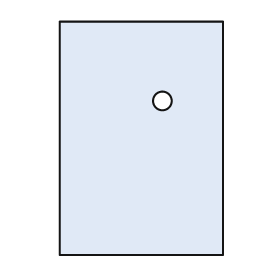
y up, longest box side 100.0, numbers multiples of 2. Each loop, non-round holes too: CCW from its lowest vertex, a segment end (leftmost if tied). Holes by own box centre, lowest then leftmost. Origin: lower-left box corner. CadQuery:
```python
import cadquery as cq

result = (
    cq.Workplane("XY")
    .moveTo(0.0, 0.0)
    .lineTo(70.0, 0.0)
    .lineTo(70.0, 100.0)
    .lineTo(0.0, 100.0)
    .close()
    .moveTo(44.0, 66.0)
    .circle(4.0)
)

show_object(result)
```